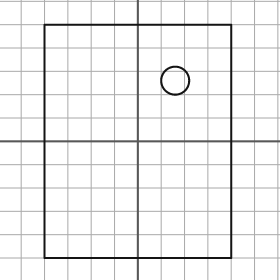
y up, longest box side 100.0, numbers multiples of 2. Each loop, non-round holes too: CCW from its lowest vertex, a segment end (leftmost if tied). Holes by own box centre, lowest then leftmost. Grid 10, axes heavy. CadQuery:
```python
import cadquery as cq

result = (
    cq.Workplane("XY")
    .moveTo(-40.0, -50.0)
    .lineTo(40.0, -50.0)
    .lineTo(40.0, 50.0)
    .lineTo(-40.0, 50.0)
    .close()
    .moveTo(16.0, 26.0)
    .circle(6.0)
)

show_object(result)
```